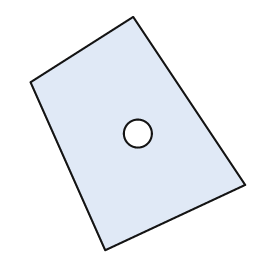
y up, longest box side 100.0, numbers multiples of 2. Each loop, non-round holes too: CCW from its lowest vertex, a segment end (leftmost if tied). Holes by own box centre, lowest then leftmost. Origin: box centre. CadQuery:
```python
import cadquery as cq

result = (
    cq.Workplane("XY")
    .moveTo(-14.0, -50.0)
    .lineTo(46.0, -22.0)
    .lineTo(-2.0, 50.0)
    .lineTo(-46.0, 22.0)
    .close()
    .moveTo(0.0, 0.0)
    .circle(6.0)
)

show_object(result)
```